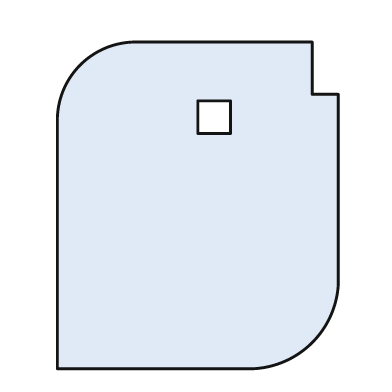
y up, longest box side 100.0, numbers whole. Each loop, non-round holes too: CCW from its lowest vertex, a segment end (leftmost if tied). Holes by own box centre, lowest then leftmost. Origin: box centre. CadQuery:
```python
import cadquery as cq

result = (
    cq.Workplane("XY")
    .moveTo(-43.0, -50.0)
    .lineTo(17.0, -50.0)
    .threePointArc((35.0, -42.0), (43.0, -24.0))
    .lineTo(43.0, 34.0)
    .lineTo(35.0, 34.0)
    .lineTo(35.0, 50.0)
    .lineTo(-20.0, 50.0)
    .threePointArc((-36.0, 43.0), (-43.0, 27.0))
    .close()
    .moveTo(0.0, 22.0)
    .lineTo(10.0, 22.0)
    .lineTo(10.0, 32.0)
    .lineTo(0.0, 32.0)
    .close()
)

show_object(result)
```